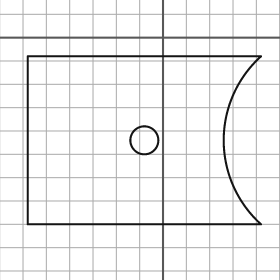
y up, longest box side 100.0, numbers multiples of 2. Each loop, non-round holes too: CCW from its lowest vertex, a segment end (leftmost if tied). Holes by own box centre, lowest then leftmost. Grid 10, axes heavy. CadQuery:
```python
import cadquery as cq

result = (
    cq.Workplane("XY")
    .moveTo(-58.0, -80.0)
    .lineTo(42.0, -80.0)
    .threePointArc((26.0, -44.0), (42.0, -8.0))
    .lineTo(-58.0, -8.0)
    .close()
    .moveTo(-8.0, -44.0)
    .circle(6.0)
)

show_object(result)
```